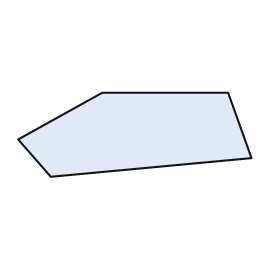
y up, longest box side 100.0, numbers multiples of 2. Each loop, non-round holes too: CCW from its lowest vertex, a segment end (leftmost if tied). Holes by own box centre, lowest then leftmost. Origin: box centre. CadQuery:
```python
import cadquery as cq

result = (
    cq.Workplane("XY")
    .moveTo(-36.0, -18.0)
    .lineTo(50.0, -10.0)
    .lineTo(40.0, 18.0)
    .lineTo(-14.0, 18.0)
    .lineTo(-50.0, -2.0)
    .close()
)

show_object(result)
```